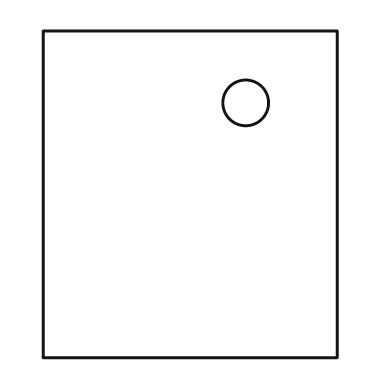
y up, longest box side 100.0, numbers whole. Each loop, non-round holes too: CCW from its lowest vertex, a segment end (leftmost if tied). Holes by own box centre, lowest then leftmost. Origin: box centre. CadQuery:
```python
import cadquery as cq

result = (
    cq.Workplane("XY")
    .moveTo(-45.0, -50.0)
    .lineTo(45.0, -50.0)
    .lineTo(45.0, 50.0)
    .lineTo(-45.0, 50.0)
    .close()
    .moveTo(17.0, 28.0)
    .circle(7.0)
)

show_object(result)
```